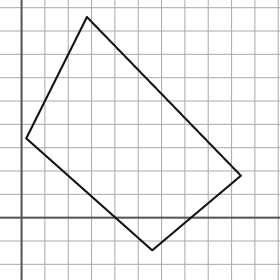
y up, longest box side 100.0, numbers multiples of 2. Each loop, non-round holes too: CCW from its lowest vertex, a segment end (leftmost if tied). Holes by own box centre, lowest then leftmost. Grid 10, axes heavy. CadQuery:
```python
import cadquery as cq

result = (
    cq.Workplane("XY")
    .moveTo(56.0, -14.0)
    .lineTo(94.0, 18.0)
    .lineTo(28.0, 86.0)
    .lineTo(2.0, 34.0)
    .close()
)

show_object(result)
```